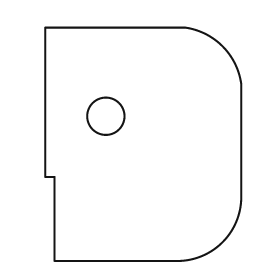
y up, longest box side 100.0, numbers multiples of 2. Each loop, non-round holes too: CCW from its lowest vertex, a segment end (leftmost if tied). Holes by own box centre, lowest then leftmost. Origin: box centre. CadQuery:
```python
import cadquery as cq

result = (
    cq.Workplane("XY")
    .moveTo(-38.0, -50.0)
    .lineTo(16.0, -50.0)
    .threePointArc((34.0, -42.0), (42.0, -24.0))
    .lineTo(42.0, 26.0)
    .threePointArc((34.0, 42.0), (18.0, 50.0))
    .lineTo(-42.0, 50.0)
    .lineTo(-42.0, -14.0)
    .lineTo(-38.0, -14.0)
    .close()
    .moveTo(-16.0, 12.0)
    .circle(8.0)
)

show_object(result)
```